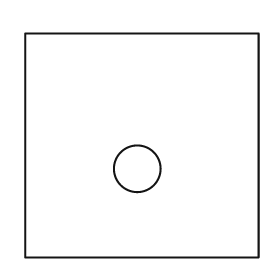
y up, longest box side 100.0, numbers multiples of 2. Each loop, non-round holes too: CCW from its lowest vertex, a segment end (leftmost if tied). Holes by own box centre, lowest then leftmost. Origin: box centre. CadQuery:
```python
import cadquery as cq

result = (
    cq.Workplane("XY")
    .moveTo(-50.0, -48.0)
    .lineTo(50.0, -48.0)
    .lineTo(50.0, 48.0)
    .lineTo(-50.0, 48.0)
    .close()
    .moveTo(-2.0, -10.0)
    .circle(10.0)
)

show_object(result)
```